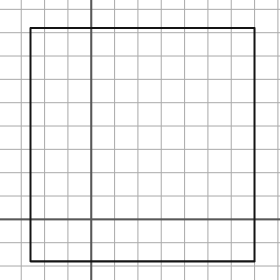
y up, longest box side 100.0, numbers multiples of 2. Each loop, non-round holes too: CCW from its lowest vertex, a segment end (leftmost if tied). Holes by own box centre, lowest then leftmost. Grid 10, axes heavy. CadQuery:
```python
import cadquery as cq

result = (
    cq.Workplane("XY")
    .moveTo(-26.0, -18.0)
    .lineTo(70.0, -18.0)
    .lineTo(70.0, 82.0)
    .lineTo(-26.0, 82.0)
    .close()
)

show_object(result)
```